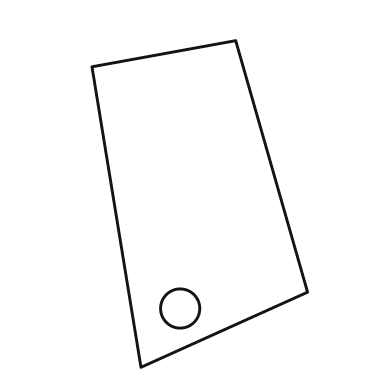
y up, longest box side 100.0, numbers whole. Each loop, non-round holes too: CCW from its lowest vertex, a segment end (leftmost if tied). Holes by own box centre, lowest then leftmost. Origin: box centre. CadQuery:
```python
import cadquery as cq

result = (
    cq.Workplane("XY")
    .moveTo(-18.0, -50.0)
    .lineTo(33.0, -27.0)
    .lineTo(11.0, 50.0)
    .lineTo(-33.0, 42.0)
    .close()
    .moveTo(-6.0, -32.0)
    .circle(6.0)
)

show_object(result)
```